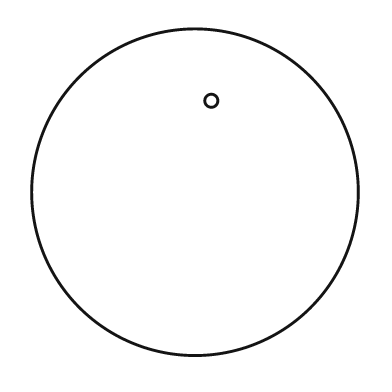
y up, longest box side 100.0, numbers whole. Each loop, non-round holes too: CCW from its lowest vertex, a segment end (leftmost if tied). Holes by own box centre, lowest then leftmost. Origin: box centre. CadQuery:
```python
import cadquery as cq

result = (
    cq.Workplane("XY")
    .moveTo(0.0, 0.0)
    .circle(50.0)
    .moveTo(5.0, 28.0)
    .circle(2.0)
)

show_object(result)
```